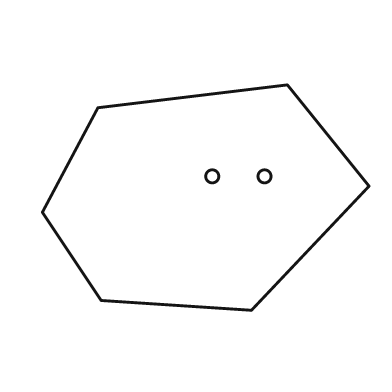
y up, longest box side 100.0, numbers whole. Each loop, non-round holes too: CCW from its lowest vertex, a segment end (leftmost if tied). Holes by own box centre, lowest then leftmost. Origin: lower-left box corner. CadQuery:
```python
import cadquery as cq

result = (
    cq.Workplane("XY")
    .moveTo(64.0, 0.0)
    .lineTo(100.0, 38.0)
    .lineTo(75.0, 69.0)
    .lineTo(17.0, 62.0)
    .lineTo(0.0, 30.0)
    .lineTo(18.0, 3.0)
    .close()
    .moveTo(52.0, 41.0)
    .circle(2.0)
    .moveTo(68.0, 41.0)
    .circle(2.0)
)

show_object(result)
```